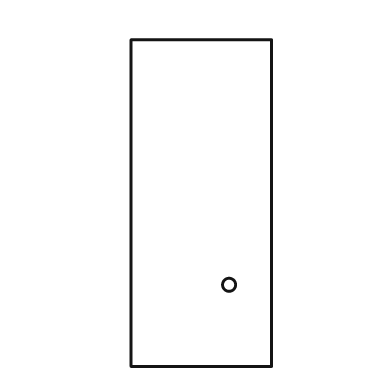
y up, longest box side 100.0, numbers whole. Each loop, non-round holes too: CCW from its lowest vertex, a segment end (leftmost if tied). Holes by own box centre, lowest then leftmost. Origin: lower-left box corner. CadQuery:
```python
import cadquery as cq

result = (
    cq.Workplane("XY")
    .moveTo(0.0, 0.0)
    .lineTo(43.0, 0.0)
    .lineTo(43.0, 100.0)
    .lineTo(0.0, 100.0)
    .close()
    .moveTo(30.0, 25.0)
    .circle(2.0)
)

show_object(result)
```